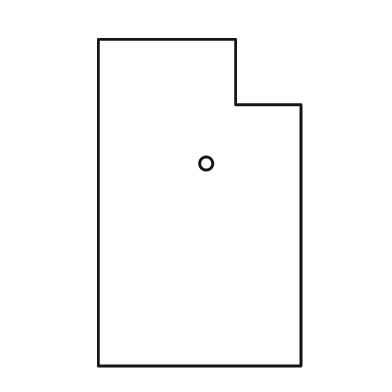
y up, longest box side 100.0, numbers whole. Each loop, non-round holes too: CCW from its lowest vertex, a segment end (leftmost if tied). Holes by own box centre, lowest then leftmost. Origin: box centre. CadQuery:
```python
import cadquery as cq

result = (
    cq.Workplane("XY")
    .moveTo(-31.0, -50.0)
    .lineTo(31.0, -50.0)
    .lineTo(31.0, 30.0)
    .lineTo(11.0, 30.0)
    .lineTo(11.0, 50.0)
    .lineTo(-31.0, 50.0)
    .close()
    .moveTo(2.0, 12.0)
    .circle(2.0)
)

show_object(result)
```